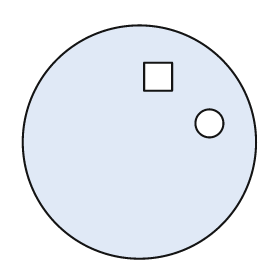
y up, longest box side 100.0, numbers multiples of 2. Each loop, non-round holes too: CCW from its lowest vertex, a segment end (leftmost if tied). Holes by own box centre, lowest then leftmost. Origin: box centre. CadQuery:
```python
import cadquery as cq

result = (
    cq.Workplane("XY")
    .moveTo(0.0, 0.0)
    .circle(50.0)
    .moveTo(30.0, 8.0)
    .circle(6.0)
    .moveTo(2.0, 22.0)
    .lineTo(14.0, 22.0)
    .lineTo(14.0, 34.0)
    .lineTo(2.0, 34.0)
    .close()
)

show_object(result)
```